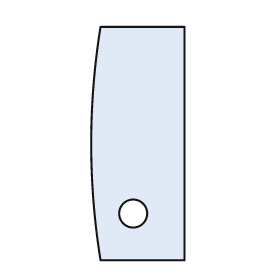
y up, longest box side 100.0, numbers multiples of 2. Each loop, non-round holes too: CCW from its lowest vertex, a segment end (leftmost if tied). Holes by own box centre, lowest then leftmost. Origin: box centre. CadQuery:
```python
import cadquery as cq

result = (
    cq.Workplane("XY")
    .moveTo(-16.0, -50.0)
    .lineTo(20.0, -50.0)
    .lineTo(20.0, 50.0)
    .lineTo(-16.0, 50.0)
    .threePointArc((-20.0, 0.0), (-16.0, -50.0))
    .close()
    .moveTo(-2.0, -30.0)
    .circle(6.0)
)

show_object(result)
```